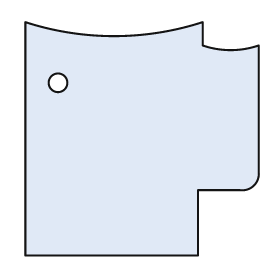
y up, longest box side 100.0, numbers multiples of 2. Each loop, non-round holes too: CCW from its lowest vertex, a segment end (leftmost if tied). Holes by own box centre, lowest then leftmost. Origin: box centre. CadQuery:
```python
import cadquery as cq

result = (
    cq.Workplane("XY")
    .moveTo(-50.0, -50.0)
    .lineTo(24.0, -50.0)
    .lineTo(24.0, -22.0)
    .lineTo(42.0, -22.0)
    .threePointArc((48.0, -20.0), (50.0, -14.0))
    .lineTo(50.0, 40.0)
    .threePointArc((38.0, 38.0), (26.0, 40.0))
    .lineTo(26.0, 50.0)
    .threePointArc((-12.0, 44.0), (-50.0, 50.0))
    .close()
    .moveTo(-36.0, 24.0)
    .circle(4.0)
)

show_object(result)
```